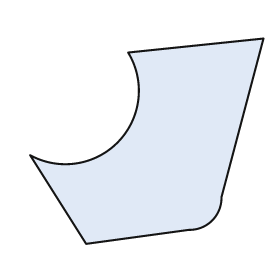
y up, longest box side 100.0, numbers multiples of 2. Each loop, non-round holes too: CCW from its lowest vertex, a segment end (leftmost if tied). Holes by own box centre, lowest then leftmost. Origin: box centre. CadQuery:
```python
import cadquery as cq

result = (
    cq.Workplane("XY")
    .moveTo(-26.0, -44.0)
    .lineTo(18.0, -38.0)
    .threePointArc((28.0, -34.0), (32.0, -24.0))
    .lineTo(50.0, 44.0)
    .lineTo(-8.0, 38.0)
    .threePointArc((-12.0, 0.0), (-50.0, -6.0))
    .close()
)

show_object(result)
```